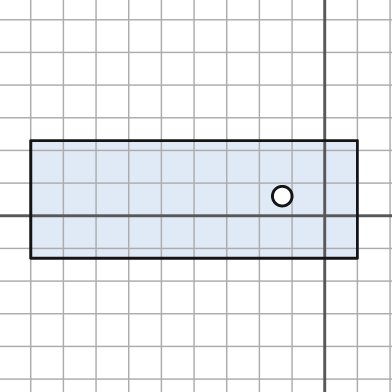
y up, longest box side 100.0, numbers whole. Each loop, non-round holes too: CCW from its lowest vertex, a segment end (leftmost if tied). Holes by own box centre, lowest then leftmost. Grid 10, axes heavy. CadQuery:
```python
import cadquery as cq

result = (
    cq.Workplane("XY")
    .moveTo(-90.0, -13.0)
    .lineTo(10.0, -13.0)
    .lineTo(10.0, 23.0)
    .lineTo(-90.0, 23.0)
    .close()
    .moveTo(-13.0, 6.0)
    .circle(3.0)
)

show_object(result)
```